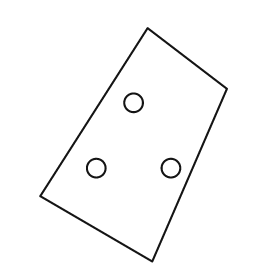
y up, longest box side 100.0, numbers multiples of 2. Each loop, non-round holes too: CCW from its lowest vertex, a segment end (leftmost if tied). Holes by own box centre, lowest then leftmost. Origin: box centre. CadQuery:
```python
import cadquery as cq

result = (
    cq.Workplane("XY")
    .moveTo(8.0, -50.0)
    .lineTo(40.0, 24.0)
    .lineTo(6.0, 50.0)
    .lineTo(-40.0, -22.0)
    .close()
    .moveTo(-16.0, -10.0)
    .circle(4.0)
    .moveTo(16.0, -10.0)
    .circle(4.0)
    .moveTo(0.0, 18.0)
    .circle(4.0)
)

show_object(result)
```